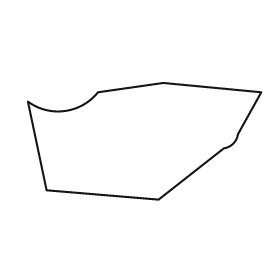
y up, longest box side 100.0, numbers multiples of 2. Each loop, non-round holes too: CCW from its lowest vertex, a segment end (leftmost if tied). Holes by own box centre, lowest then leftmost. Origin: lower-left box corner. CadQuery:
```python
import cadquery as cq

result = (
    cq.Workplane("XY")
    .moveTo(56.0, 0.0)
    .lineTo(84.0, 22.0)
    .threePointArc((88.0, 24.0), (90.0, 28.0))
    .lineTo(100.0, 46.0)
    .lineTo(58.0, 50.0)
    .lineTo(30.0, 46.0)
    .threePointArc((16.0, 38.0), (0.0, 42.0))
    .lineTo(8.0, 4.0)
    .close()
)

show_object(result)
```